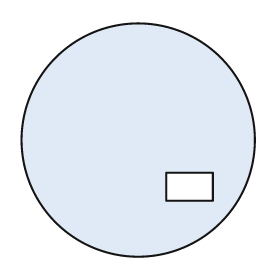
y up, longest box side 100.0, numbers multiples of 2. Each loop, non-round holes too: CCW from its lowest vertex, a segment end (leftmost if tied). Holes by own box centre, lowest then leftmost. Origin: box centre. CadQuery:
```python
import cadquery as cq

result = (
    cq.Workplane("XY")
    .moveTo(0.0, 0.0)
    .circle(50.0)
    .moveTo(12.0, -26.0)
    .lineTo(32.0, -26.0)
    .lineTo(32.0, -14.0)
    .lineTo(12.0, -14.0)
    .close()
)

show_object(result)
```